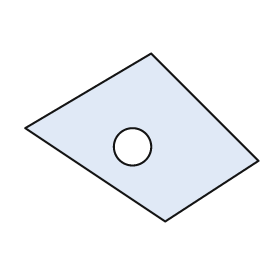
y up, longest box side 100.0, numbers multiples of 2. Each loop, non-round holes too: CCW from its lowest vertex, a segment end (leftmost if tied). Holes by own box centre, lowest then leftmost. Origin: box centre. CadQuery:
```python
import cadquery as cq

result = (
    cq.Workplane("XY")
    .moveTo(10.0, -36.0)
    .lineTo(50.0, -10.0)
    .lineTo(4.0, 36.0)
    .lineTo(-50.0, 4.0)
    .close()
    .moveTo(-4.0, -4.0)
    .circle(8.0)
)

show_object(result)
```